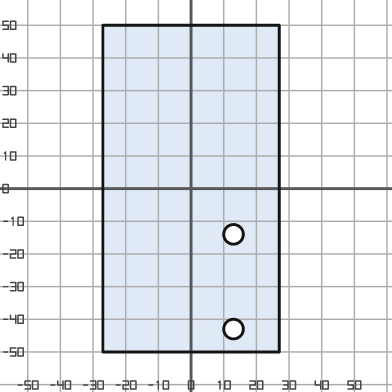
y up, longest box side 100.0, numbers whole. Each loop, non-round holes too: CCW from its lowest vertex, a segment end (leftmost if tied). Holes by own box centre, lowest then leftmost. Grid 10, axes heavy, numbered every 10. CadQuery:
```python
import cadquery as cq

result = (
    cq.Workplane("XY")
    .moveTo(-27.0, -50.0)
    .lineTo(27.0, -50.0)
    .lineTo(27.0, 50.0)
    .lineTo(-27.0, 50.0)
    .close()
    .moveTo(13.0, -43.0)
    .circle(3.0)
    .moveTo(13.0, -14.0)
    .circle(3.0)
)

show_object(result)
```